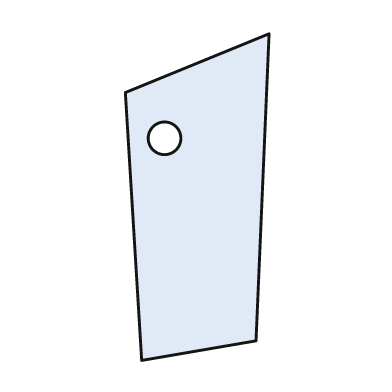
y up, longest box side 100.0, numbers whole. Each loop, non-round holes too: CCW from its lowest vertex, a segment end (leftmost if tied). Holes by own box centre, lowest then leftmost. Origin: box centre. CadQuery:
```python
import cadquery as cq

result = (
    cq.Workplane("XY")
    .moveTo(-17.0, -50.0)
    .lineTo(18.0, -44.0)
    .lineTo(22.0, 50.0)
    .lineTo(-22.0, 32.0)
    .close()
    .moveTo(-10.0, 18.0)
    .circle(5.0)
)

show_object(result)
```